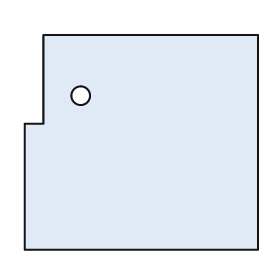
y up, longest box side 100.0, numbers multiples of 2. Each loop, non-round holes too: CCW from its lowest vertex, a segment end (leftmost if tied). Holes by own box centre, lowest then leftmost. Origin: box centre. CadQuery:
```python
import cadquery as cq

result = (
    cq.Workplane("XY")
    .moveTo(-50.0, -46.0)
    .lineTo(50.0, -46.0)
    .lineTo(50.0, 46.0)
    .lineTo(-42.0, 46.0)
    .lineTo(-42.0, 8.0)
    .lineTo(-50.0, 8.0)
    .close()
    .moveTo(-26.0, 20.0)
    .circle(4.0)
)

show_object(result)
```